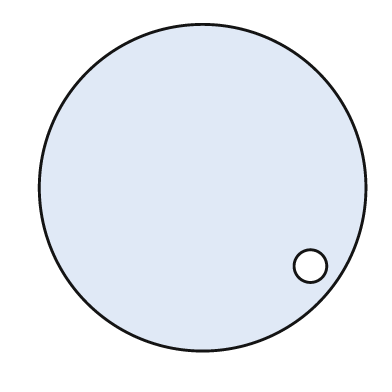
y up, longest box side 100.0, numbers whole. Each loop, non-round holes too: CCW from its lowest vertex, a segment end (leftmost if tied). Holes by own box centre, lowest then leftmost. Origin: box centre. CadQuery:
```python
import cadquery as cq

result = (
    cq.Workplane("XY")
    .moveTo(0.0, 0.0)
    .circle(50.0)
    .moveTo(33.0, -24.0)
    .circle(5.0)
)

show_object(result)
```